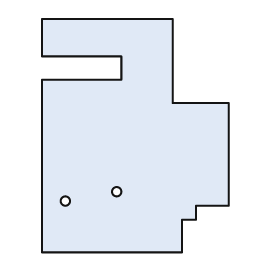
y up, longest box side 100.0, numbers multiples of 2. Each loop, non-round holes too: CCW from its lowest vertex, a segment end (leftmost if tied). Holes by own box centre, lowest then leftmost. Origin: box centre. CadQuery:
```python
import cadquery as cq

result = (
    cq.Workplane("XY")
    .moveTo(-40.0, -50.0)
    .lineTo(20.0, -50.0)
    .lineTo(20.0, -36.0)
    .lineTo(26.0, -36.0)
    .lineTo(26.0, -30.0)
    .lineTo(40.0, -30.0)
    .lineTo(40.0, 14.0)
    .lineTo(16.0, 14.0)
    .lineTo(16.0, 50.0)
    .lineTo(-40.0, 50.0)
    .lineTo(-40.0, 34.0)
    .lineTo(-6.0, 34.0)
    .lineTo(-6.0, 24.0)
    .lineTo(-40.0, 24.0)
    .close()
    .moveTo(-30.0, -28.0)
    .circle(2.0)
    .moveTo(-8.0, -24.0)
    .circle(2.0)
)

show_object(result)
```